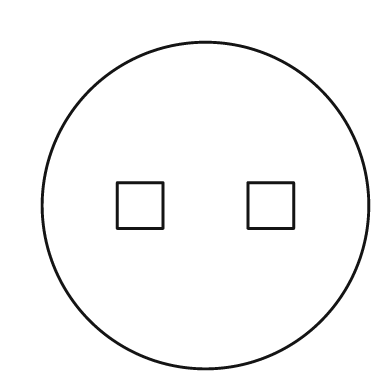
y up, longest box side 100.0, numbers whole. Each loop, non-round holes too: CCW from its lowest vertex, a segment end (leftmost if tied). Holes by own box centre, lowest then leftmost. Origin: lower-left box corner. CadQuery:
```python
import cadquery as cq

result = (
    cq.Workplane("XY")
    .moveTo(50.0, 50.0)
    .circle(50.0)
    .moveTo(23.0, 43.0)
    .lineTo(37.0, 43.0)
    .lineTo(37.0, 57.0)
    .lineTo(23.0, 57.0)
    .close()
    .moveTo(63.0, 43.0)
    .lineTo(77.0, 43.0)
    .lineTo(77.0, 57.0)
    .lineTo(63.0, 57.0)
    .close()
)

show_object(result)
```